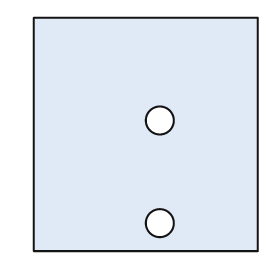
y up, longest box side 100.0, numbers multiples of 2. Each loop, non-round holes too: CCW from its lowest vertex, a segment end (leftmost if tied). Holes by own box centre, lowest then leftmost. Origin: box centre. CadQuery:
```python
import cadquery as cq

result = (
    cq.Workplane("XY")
    .moveTo(-48.0, -50.0)
    .lineTo(48.0, -50.0)
    .lineTo(48.0, 50.0)
    .lineTo(-48.0, 50.0)
    .close()
    .moveTo(6.0, -38.0)
    .circle(6.0)
    .moveTo(6.0, 6.0)
    .circle(6.0)
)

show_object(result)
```